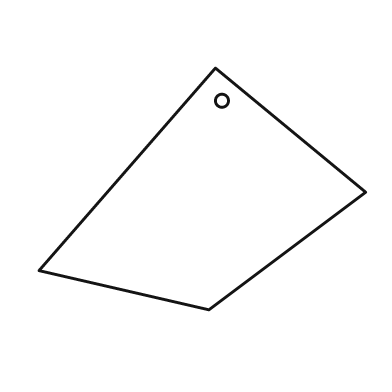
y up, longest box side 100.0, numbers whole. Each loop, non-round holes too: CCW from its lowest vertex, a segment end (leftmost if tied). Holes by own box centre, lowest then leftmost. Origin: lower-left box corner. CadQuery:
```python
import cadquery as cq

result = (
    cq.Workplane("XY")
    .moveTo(52.0, 0.0)
    .lineTo(100.0, 36.0)
    .lineTo(54.0, 74.0)
    .lineTo(0.0, 12.0)
    .close()
    .moveTo(56.0, 64.0)
    .circle(2.0)
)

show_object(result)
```